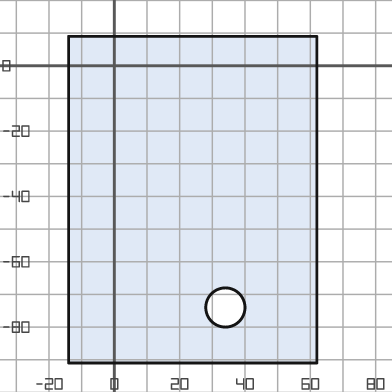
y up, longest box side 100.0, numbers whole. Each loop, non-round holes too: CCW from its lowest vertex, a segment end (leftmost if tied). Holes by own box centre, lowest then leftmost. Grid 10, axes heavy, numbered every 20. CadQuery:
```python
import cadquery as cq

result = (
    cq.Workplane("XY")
    .moveTo(-14.0, -91.0)
    .lineTo(62.0, -91.0)
    .lineTo(62.0, 9.0)
    .lineTo(-14.0, 9.0)
    .close()
    .moveTo(34.0, -74.0)
    .circle(6.0)
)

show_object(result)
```